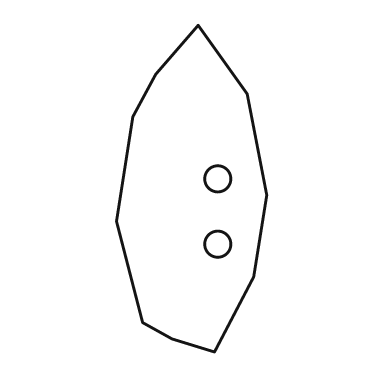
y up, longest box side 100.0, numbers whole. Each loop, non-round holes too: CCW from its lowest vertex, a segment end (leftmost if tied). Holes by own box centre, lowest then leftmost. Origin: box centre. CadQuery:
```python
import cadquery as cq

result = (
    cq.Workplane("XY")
    .moveTo(7.0, -50.0)
    .lineTo(19.0, -27.0)
    .lineTo(23.0, -2.0)
    .lineTo(17.0, 29.0)
    .lineTo(2.0, 50.0)
    .lineTo(-11.0, 35.0)
    .lineTo(-18.0, 22.0)
    .lineTo(-23.0, -10.0)
    .lineTo(-15.0, -41.0)
    .lineTo(-6.0, -46.0)
    .close()
    .moveTo(8.0, -17.0)
    .circle(4.0)
    .moveTo(8.0, 3.0)
    .circle(4.0)
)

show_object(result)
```